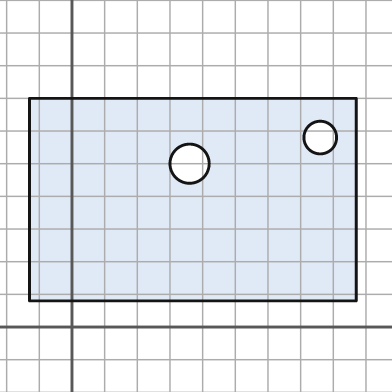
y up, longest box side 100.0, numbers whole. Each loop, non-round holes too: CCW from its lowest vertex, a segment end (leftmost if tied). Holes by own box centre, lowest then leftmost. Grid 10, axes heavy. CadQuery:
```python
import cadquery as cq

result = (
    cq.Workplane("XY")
    .moveTo(-13.0, 8.0)
    .lineTo(87.0, 8.0)
    .lineTo(87.0, 70.0)
    .lineTo(-13.0, 70.0)
    .close()
    .moveTo(36.0, 50.0)
    .circle(6.0)
    .moveTo(76.0, 58.0)
    .circle(5.0)
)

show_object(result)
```